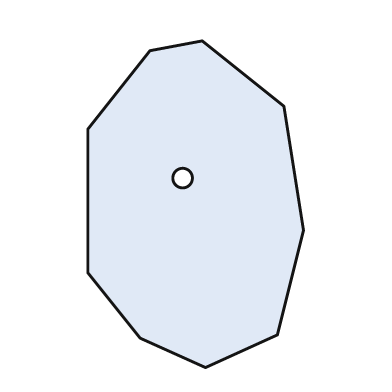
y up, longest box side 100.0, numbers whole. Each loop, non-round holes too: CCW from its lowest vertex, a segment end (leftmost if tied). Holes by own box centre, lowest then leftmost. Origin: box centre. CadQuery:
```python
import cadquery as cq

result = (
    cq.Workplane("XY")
    .moveTo(3.0, -50.0)
    .lineTo(25.0, -40.0)
    .lineTo(33.0, -8.0)
    .lineTo(27.0, 30.0)
    .lineTo(2.0, 50.0)
    .lineTo(-14.0, 47.0)
    .lineTo(-33.0, 23.0)
    .lineTo(-33.0, -21.0)
    .lineTo(-17.0, -41.0)
    .close()
    .moveTo(-4.0, 8.0)
    .circle(3.0)
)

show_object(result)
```